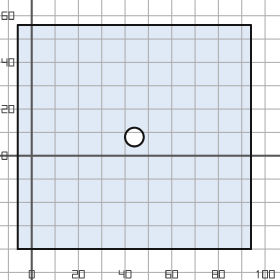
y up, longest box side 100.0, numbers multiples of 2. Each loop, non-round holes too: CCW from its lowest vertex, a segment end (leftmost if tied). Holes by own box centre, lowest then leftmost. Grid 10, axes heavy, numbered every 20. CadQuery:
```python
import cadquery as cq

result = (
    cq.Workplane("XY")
    .moveTo(-6.0, -40.0)
    .lineTo(94.0, -40.0)
    .lineTo(94.0, 56.0)
    .lineTo(-6.0, 56.0)
    .close()
    .moveTo(44.0, 8.0)
    .circle(4.0)
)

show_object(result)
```